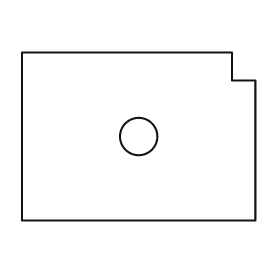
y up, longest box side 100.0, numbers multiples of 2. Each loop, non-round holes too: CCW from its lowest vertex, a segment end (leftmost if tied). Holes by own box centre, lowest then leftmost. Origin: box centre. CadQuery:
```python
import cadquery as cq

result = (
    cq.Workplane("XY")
    .moveTo(-50.0, -36.0)
    .lineTo(50.0, -36.0)
    .lineTo(50.0, 24.0)
    .lineTo(40.0, 24.0)
    .lineTo(40.0, 36.0)
    .lineTo(-50.0, 36.0)
    .close()
    .moveTo(0.0, 0.0)
    .circle(8.0)
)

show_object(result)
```